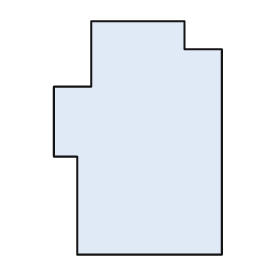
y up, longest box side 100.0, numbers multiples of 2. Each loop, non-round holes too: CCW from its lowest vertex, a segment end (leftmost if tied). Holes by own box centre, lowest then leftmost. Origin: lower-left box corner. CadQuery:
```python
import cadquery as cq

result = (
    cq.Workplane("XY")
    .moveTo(10.0, 0.0)
    .lineTo(72.0, 0.0)
    .lineTo(72.0, 88.0)
    .lineTo(56.0, 88.0)
    .lineTo(56.0, 100.0)
    .lineTo(16.0, 100.0)
    .lineTo(16.0, 72.0)
    .lineTo(0.0, 72.0)
    .lineTo(0.0, 42.0)
    .lineTo(10.0, 42.0)
    .close()
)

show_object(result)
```